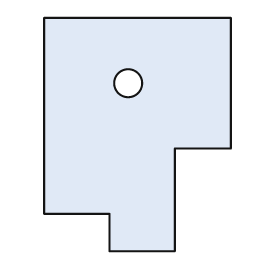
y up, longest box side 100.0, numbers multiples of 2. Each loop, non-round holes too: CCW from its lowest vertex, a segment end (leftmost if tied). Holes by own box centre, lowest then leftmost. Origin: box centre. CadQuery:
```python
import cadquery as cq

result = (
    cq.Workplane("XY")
    .moveTo(-12.0, -50.0)
    .lineTo(16.0, -50.0)
    .lineTo(16.0, -6.0)
    .lineTo(40.0, -6.0)
    .lineTo(40.0, 50.0)
    .lineTo(-40.0, 50.0)
    .lineTo(-40.0, -34.0)
    .lineTo(-12.0, -34.0)
    .close()
    .moveTo(-4.0, 22.0)
    .circle(6.0)
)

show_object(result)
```